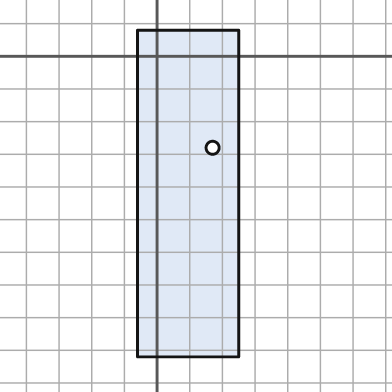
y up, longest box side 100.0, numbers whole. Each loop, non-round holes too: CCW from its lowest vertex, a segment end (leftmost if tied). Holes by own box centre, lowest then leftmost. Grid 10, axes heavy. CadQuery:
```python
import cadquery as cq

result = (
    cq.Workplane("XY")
    .moveTo(-6.0, -92.0)
    .lineTo(25.0, -92.0)
    .lineTo(25.0, 8.0)
    .lineTo(-6.0, 8.0)
    .close()
    .moveTo(17.0, -28.0)
    .circle(2.0)
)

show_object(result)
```